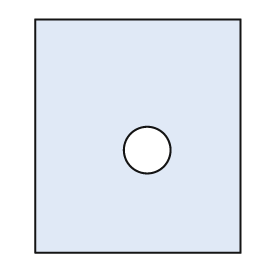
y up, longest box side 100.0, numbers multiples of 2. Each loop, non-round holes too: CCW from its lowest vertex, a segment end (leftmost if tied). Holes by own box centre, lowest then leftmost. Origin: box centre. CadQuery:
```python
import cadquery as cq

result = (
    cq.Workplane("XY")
    .moveTo(-44.0, -50.0)
    .lineTo(44.0, -50.0)
    .lineTo(44.0, 50.0)
    .lineTo(-44.0, 50.0)
    .close()
    .moveTo(4.0, -6.0)
    .circle(10.0)
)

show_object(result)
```